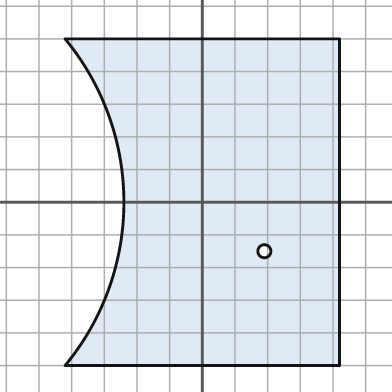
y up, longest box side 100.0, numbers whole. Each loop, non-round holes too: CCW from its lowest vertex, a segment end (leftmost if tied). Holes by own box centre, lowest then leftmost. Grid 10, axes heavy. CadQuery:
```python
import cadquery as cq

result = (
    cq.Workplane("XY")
    .moveTo(-42.0, -50.0)
    .lineTo(42.0, -50.0)
    .lineTo(42.0, 50.0)
    .lineTo(-42.0, 50.0)
    .threePointArc((-24.0, 0.0), (-42.0, -50.0))
    .close()
    .moveTo(19.0, -15.0)
    .circle(2.0)
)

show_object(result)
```